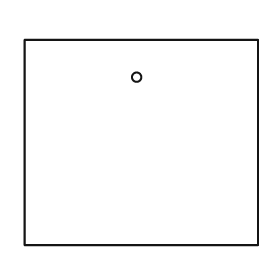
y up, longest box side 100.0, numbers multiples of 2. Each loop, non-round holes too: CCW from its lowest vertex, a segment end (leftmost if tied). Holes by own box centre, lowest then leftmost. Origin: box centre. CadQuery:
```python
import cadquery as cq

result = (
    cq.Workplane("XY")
    .moveTo(-50.0, -44.0)
    .lineTo(50.0, -44.0)
    .lineTo(50.0, 44.0)
    .lineTo(-50.0, 44.0)
    .close()
    .moveTo(-2.0, 28.0)
    .circle(2.0)
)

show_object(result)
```